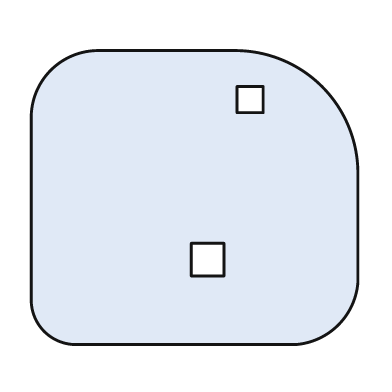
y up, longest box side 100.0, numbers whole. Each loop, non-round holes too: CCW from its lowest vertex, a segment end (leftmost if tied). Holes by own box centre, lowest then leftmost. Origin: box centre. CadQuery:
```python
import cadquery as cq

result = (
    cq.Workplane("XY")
    .moveTo(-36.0, -45.0)
    .lineTo(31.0, -45.0)
    .threePointArc((44.0, -39.0), (50.0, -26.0))
    .lineTo(50.0, 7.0)
    .threePointArc((39.0, 34.0), (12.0, 45.0))
    .lineTo(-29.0, 45.0)
    .threePointArc((-44.0, 39.0), (-50.0, 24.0))
    .lineTo(-50.0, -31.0)
    .threePointArc((-46.0, -41.0), (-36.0, -45.0))
    .close()
    .moveTo(-1.0, -24.0)
    .lineTo(9.0, -24.0)
    .lineTo(9.0, -14.0)
    .lineTo(-1.0, -14.0)
    .close()
    .moveTo(13.0, 26.0)
    .lineTo(21.0, 26.0)
    .lineTo(21.0, 34.0)
    .lineTo(13.0, 34.0)
    .close()
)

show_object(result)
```